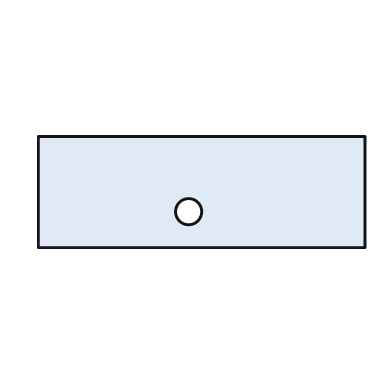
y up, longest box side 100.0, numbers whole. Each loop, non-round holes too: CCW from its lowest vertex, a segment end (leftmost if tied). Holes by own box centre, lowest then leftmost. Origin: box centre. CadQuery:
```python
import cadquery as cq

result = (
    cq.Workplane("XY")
    .moveTo(-50.0, -17.0)
    .lineTo(50.0, -17.0)
    .lineTo(50.0, 17.0)
    .lineTo(-50.0, 17.0)
    .close()
    .moveTo(-4.0, -6.0)
    .circle(4.0)
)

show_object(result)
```